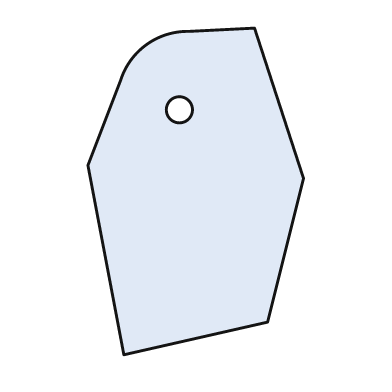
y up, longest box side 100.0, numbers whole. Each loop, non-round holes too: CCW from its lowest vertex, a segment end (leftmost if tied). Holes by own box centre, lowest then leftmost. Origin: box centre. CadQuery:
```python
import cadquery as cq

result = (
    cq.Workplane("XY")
    .moveTo(-22.0, -50.0)
    .lineTo(22.0, -40.0)
    .lineTo(33.0, 4.0)
    .lineTo(18.0, 50.0)
    .lineTo(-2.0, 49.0)
    .threePointArc((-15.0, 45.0), (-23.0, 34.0))
    .lineTo(-33.0, 8.0)
    .close()
    .moveTo(-5.0, 25.0)
    .circle(4.0)
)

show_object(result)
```